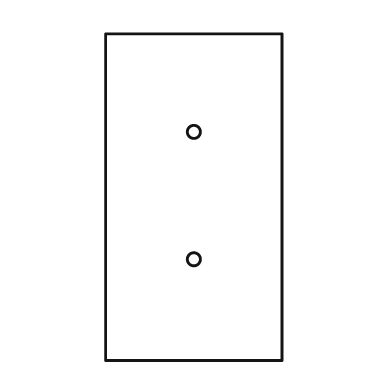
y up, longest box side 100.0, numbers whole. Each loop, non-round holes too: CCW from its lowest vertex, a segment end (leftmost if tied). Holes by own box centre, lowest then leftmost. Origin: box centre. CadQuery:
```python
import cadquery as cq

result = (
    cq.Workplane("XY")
    .moveTo(-27.0, -50.0)
    .lineTo(27.0, -50.0)
    .lineTo(27.0, 50.0)
    .lineTo(-27.0, 50.0)
    .close()
    .moveTo(0.0, -19.0)
    .circle(2.0)
    .moveTo(0.0, 20.0)
    .circle(2.0)
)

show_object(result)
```